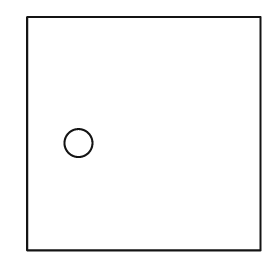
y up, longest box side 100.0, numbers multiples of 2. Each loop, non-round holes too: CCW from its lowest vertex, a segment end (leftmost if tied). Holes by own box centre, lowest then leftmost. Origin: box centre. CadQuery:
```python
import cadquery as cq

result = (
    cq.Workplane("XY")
    .moveTo(-50.0, -50.0)
    .lineTo(50.0, -50.0)
    .lineTo(50.0, 50.0)
    .lineTo(-50.0, 50.0)
    .close()
    .moveTo(-28.0, -4.0)
    .circle(6.0)
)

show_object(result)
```